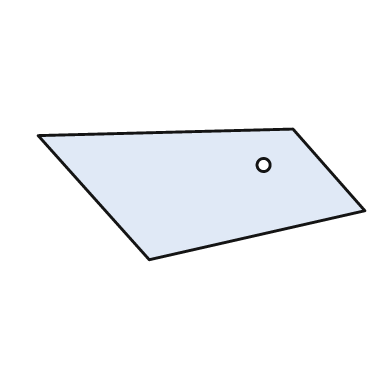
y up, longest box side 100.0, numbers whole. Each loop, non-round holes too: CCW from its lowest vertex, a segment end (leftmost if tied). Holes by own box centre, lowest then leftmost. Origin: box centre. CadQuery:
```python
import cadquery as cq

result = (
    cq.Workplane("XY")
    .moveTo(-16.0, -20.0)
    .lineTo(50.0, -5.0)
    .lineTo(28.0, 20.0)
    .lineTo(-50.0, 18.0)
    .close()
    .moveTo(19.0, 9.0)
    .circle(2.0)
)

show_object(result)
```